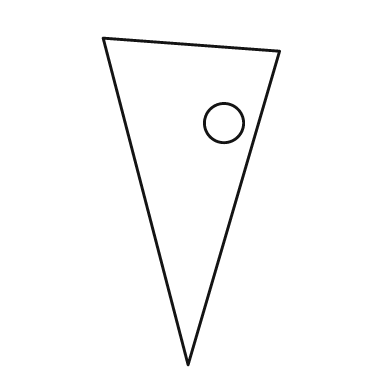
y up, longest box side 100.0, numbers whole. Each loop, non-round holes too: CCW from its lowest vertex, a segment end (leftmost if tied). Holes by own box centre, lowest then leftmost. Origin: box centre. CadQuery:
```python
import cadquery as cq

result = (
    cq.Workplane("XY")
    .moveTo(-1.0, -50.0)
    .lineTo(27.0, 46.0)
    .lineTo(-27.0, 50.0)
    .close()
    .moveTo(10.0, 24.0)
    .circle(6.0)
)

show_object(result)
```